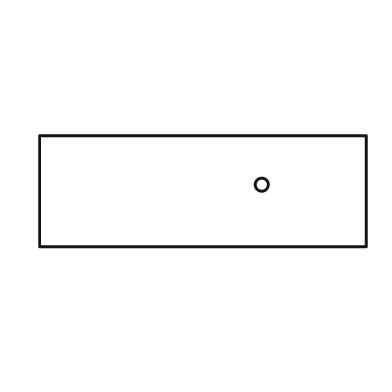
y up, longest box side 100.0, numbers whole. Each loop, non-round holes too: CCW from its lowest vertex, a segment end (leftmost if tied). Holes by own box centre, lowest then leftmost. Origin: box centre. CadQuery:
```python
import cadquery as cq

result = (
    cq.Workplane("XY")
    .moveTo(-50.0, -17.0)
    .lineTo(50.0, -17.0)
    .lineTo(50.0, 17.0)
    .lineTo(-50.0, 17.0)
    .close()
    .moveTo(18.0, 2.0)
    .circle(2.0)
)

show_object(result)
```